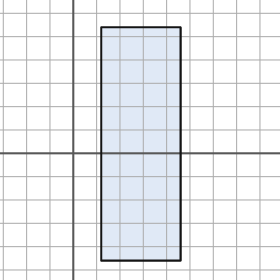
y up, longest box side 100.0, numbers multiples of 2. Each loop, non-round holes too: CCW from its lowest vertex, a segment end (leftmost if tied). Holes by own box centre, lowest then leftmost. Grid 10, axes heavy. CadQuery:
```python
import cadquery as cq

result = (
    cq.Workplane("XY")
    .moveTo(12.0, -46.0)
    .lineTo(46.0, -46.0)
    .lineTo(46.0, 54.0)
    .lineTo(12.0, 54.0)
    .close()
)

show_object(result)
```